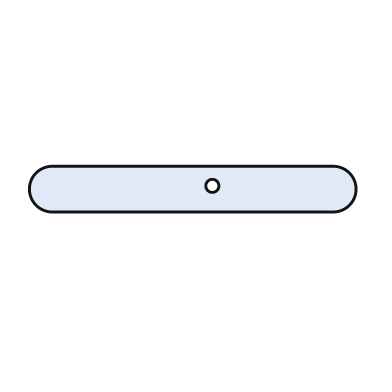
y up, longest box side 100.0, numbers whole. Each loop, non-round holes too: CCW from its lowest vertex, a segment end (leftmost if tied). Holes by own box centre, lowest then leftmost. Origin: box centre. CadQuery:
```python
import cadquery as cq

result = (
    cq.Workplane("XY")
    .moveTo(-43.0, -7.0)
    .lineTo(43.0, -7.0)
    .threePointArc((50.0, 0.0), (43.0, 7.0))
    .lineTo(-43.0, 7.0)
    .threePointArc((-50.0, 0.0), (-43.0, -7.0))
    .close()
    .moveTo(6.0, 1.0)
    .circle(2.0)
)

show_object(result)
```